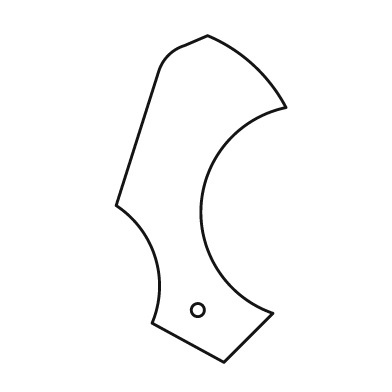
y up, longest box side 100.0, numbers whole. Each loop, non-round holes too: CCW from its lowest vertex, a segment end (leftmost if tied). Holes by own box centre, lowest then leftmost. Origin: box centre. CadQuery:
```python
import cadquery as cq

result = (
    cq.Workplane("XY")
    .moveTo(7.0, -50.0)
    .lineTo(22.0, -35.0)
    .threePointArc((0.0, -2.0), (26.0, 28.0))
    .threePointArc((16.0, 41.0), (2.0, 50.0))
    .lineTo(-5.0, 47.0)
    .threePointArc((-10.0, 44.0), (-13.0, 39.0))
    .lineTo(-26.0, -2.0)
    .threePointArc((-14.0, -18.0), (-15.0, -38.0))
    .close()
    .moveTo(-1.0, -34.0)
    .circle(2.0)
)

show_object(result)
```